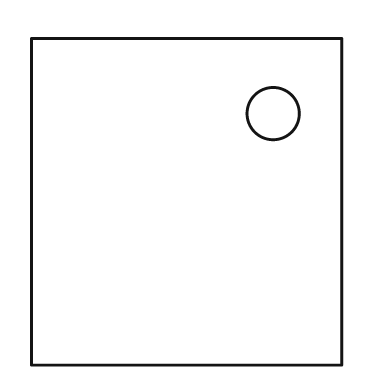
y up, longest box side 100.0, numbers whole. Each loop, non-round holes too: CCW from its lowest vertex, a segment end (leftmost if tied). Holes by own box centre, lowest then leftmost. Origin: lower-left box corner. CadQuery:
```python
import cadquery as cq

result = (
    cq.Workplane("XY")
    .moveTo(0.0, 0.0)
    .lineTo(95.0, 0.0)
    .lineTo(95.0, 100.0)
    .lineTo(0.0, 100.0)
    .close()
    .moveTo(74.0, 77.0)
    .circle(8.0)
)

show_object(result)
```